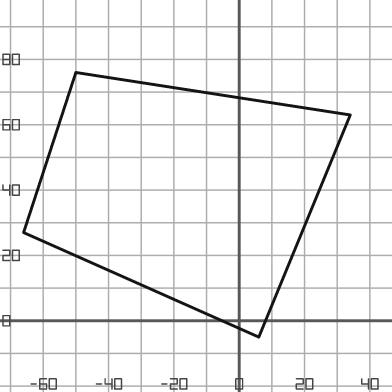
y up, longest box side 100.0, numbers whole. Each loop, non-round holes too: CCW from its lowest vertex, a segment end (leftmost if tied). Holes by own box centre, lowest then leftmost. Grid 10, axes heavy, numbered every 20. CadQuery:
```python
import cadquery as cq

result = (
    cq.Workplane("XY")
    .moveTo(6.0, -5.0)
    .lineTo(34.0, 63.0)
    .lineTo(-50.0, 76.0)
    .lineTo(-66.0, 27.0)
    .close()
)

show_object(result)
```